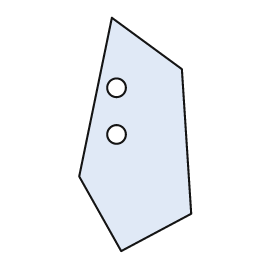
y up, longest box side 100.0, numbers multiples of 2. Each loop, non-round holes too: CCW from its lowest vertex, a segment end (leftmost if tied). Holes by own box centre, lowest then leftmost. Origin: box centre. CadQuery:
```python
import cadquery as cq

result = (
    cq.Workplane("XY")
    .moveTo(-6.0, -50.0)
    .lineTo(24.0, -34.0)
    .lineTo(20.0, 28.0)
    .lineTo(-10.0, 50.0)
    .lineTo(-24.0, -18.0)
    .close()
    .moveTo(-8.0, 0.0)
    .circle(4.0)
    .moveTo(-8.0, 20.0)
    .circle(4.0)
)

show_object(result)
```